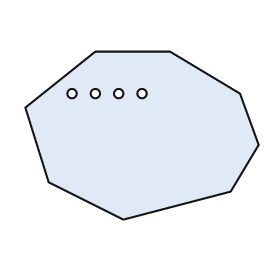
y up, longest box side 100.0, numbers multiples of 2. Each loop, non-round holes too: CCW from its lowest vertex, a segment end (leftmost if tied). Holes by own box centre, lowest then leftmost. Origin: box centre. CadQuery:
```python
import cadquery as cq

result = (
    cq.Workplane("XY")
    .moveTo(-8.0, -36.0)
    .lineTo(38.0, -24.0)
    .lineTo(50.0, -4.0)
    .lineTo(42.0, 18.0)
    .lineTo(12.0, 36.0)
    .lineTo(-20.0, 36.0)
    .lineTo(-50.0, 12.0)
    .lineTo(-40.0, -20.0)
    .close()
    .moveTo(-30.0, 18.0)
    .circle(2.0)
    .moveTo(-20.0, 18.0)
    .circle(2.0)
    .moveTo(-10.0, 18.0)
    .circle(2.0)
    .moveTo(0.0, 18.0)
    .circle(2.0)
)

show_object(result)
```